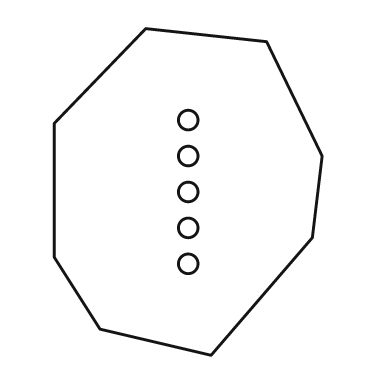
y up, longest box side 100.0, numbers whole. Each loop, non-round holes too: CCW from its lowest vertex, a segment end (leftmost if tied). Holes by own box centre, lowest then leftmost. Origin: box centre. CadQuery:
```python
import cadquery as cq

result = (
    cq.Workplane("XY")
    .moveTo(7.0, -50.0)
    .lineTo(38.0, -14.0)
    .lineTo(41.0, 11.0)
    .lineTo(24.0, 46.0)
    .lineTo(-13.0, 50.0)
    .lineTo(-41.0, 21.0)
    .lineTo(-41.0, -20.0)
    .lineTo(-27.0, -42.0)
    .close()
    .moveTo(0.0, -22.0)
    .circle(3.0)
    .moveTo(0.0, -11.0)
    .circle(3.0)
    .moveTo(0.0, 0.0)
    .circle(3.0)
    .moveTo(0.0, 11.0)
    .circle(3.0)
    .moveTo(0.0, 22.0)
    .circle(3.0)
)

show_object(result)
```